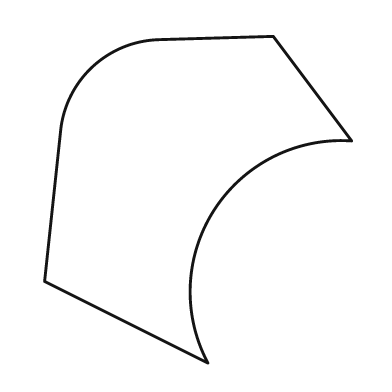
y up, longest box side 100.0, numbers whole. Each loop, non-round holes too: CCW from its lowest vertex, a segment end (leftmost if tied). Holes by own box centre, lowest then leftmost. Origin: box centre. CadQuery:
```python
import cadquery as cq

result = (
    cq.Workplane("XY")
    .moveTo(3.0, -50.0)
    .threePointArc((5.0, -3.0), (47.0, 18.0))
    .lineTo(23.0, 50.0)
    .lineTo(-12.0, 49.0)
    .threePointArc((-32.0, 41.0), (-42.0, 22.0))
    .lineTo(-47.0, -25.0)
    .close()
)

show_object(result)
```